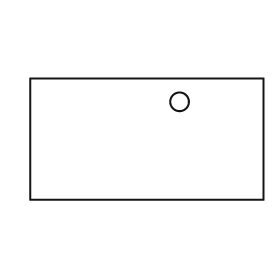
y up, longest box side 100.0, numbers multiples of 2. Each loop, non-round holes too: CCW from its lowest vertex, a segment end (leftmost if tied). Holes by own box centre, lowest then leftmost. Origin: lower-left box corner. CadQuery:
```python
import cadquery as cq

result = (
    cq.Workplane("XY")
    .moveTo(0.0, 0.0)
    .lineTo(100.0, 0.0)
    .lineTo(100.0, 52.0)
    .lineTo(0.0, 52.0)
    .close()
    .moveTo(64.0, 42.0)
    .circle(4.0)
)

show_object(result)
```